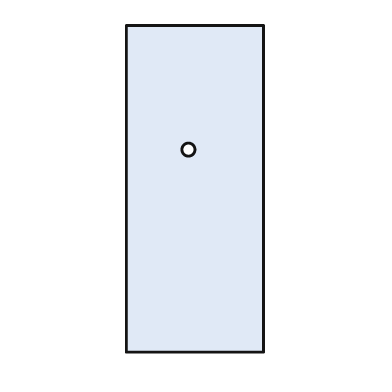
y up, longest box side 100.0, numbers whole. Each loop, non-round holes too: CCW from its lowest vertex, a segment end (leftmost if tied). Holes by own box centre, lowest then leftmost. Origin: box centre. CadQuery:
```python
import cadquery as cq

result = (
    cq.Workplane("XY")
    .moveTo(-21.0, -50.0)
    .lineTo(21.0, -50.0)
    .lineTo(21.0, 50.0)
    .lineTo(-21.0, 50.0)
    .close()
    .moveTo(-2.0, 12.0)
    .circle(2.0)
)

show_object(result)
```